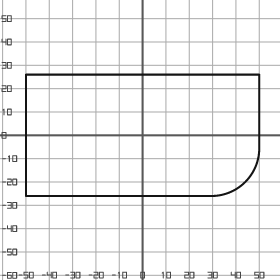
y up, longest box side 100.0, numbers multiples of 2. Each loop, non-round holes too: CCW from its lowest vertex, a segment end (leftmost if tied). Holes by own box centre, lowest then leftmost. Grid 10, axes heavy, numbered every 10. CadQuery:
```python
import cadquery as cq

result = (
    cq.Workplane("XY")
    .moveTo(-50.0, -26.0)
    .lineTo(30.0, -26.0)
    .threePointArc((44.0, -20.0), (50.0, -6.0))
    .lineTo(50.0, 26.0)
    .lineTo(-50.0, 26.0)
    .close()
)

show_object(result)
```